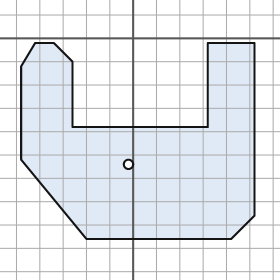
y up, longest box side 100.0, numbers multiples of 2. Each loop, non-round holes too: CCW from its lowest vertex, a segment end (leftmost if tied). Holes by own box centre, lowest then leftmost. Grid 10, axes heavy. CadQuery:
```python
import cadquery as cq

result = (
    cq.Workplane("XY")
    .moveTo(-20.0, -86.0)
    .lineTo(42.0, -86.0)
    .lineTo(52.0, -76.0)
    .lineTo(52.0, -2.0)
    .lineTo(32.0, -2.0)
    .lineTo(32.0, -38.0)
    .lineTo(-26.0, -38.0)
    .lineTo(-26.0, -10.0)
    .lineTo(-34.0, -2.0)
    .lineTo(-42.0, -2.0)
    .lineTo(-48.0, -12.0)
    .lineTo(-48.0, -52.0)
    .close()
    .moveTo(-2.0, -54.0)
    .circle(2.0)
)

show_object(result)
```